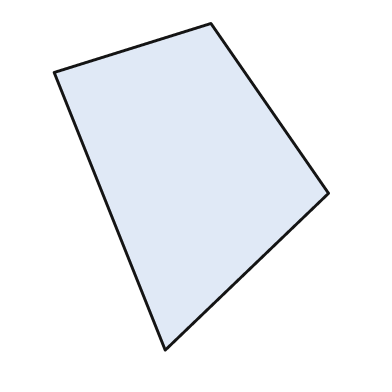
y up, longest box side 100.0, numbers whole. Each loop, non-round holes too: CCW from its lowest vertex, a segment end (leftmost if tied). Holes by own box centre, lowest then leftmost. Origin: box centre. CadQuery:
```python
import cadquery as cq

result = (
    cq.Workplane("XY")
    .moveTo(-8.0, -50.0)
    .lineTo(42.0, -2.0)
    .lineTo(6.0, 50.0)
    .lineTo(-42.0, 35.0)
    .close()
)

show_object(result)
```